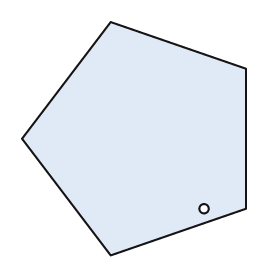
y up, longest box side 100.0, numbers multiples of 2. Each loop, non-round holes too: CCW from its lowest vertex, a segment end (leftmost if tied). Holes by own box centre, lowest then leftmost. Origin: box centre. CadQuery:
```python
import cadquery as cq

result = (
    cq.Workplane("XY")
    .moveTo(-10.0, -50.0)
    .lineTo(48.0, -30.0)
    .lineTo(48.0, 30.0)
    .lineTo(-10.0, 50.0)
    .lineTo(-48.0, 0.0)
    .close()
    .moveTo(30.0, -30.0)
    .circle(2.0)
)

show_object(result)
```